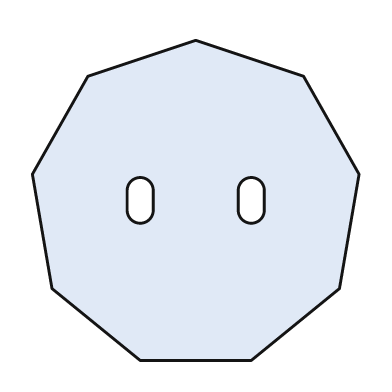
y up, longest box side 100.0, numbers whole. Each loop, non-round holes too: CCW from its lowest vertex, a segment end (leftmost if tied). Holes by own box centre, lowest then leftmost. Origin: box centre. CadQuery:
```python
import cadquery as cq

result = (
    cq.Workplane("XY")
    .moveTo(-17.0, -49.0)
    .lineTo(17.0, -49.0)
    .lineTo(44.0, -27.0)
    .lineTo(50.0, 8.0)
    .lineTo(33.0, 38.0)
    .lineTo(0.0, 49.0)
    .lineTo(-33.0, 38.0)
    .lineTo(-50.0, 8.0)
    .lineTo(-44.0, -27.0)
    .close()
    .moveTo(-21.0, -3.0)
    .threePointArc((-17.0, -7.0), (-13.0, -3.0))
    .lineTo(-13.0, 3.0)
    .threePointArc((-17.0, 7.0), (-21.0, 3.0))
    .close()
    .moveTo(13.0, -3.0)
    .threePointArc((17.0, -7.0), (21.0, -3.0))
    .lineTo(21.0, 3.0)
    .threePointArc((17.0, 7.0), (13.0, 3.0))
    .close()
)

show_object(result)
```